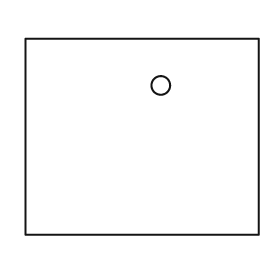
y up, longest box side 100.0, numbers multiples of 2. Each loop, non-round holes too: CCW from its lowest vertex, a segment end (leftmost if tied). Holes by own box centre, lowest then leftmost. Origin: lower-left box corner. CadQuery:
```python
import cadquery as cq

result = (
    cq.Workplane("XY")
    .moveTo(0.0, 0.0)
    .lineTo(100.0, 0.0)
    .lineTo(100.0, 84.0)
    .lineTo(0.0, 84.0)
    .close()
    .moveTo(58.0, 64.0)
    .circle(4.0)
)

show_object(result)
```